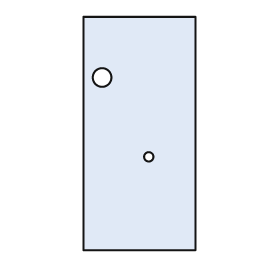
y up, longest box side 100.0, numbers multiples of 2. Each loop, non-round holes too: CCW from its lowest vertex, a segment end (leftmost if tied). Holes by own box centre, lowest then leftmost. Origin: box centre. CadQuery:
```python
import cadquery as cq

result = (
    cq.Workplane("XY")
    .moveTo(-24.0, -50.0)
    .lineTo(24.0, -50.0)
    .lineTo(24.0, 50.0)
    .lineTo(-24.0, 50.0)
    .close()
    .moveTo(4.0, -10.0)
    .circle(2.0)
    .moveTo(-16.0, 24.0)
    .circle(4.0)
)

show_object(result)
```